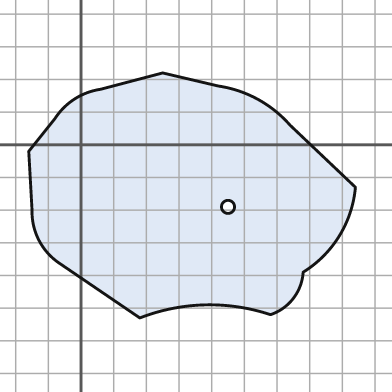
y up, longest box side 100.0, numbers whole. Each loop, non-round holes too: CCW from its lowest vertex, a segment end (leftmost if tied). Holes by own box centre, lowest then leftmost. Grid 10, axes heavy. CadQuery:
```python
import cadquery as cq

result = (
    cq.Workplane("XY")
    .moveTo(18.0, -53.0)
    .threePointArc((38.0, -49.0), (58.0, -52.0))
    .threePointArc((65.0, -47.0), (68.0, -39.0))
    .threePointArc((79.0, -28.0), (84.0, -13.0))
    .lineTo(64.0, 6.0)
    .threePointArc((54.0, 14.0), (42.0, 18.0))
    .lineTo(25.0, 22.0)
    .lineTo(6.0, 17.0)
    .threePointArc((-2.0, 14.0), (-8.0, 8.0))
    .lineTo(-16.0, -2.0)
    .lineTo(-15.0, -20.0)
    .threePointArc((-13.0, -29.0), (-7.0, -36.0))
    .close()
    .moveTo(45.0, -19.0)
    .circle(2.0)
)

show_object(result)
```